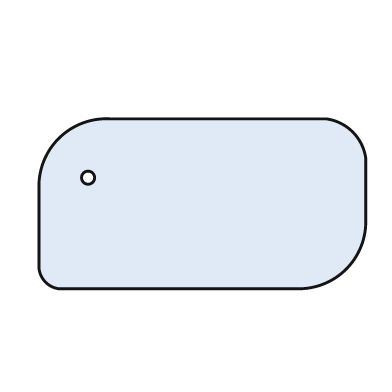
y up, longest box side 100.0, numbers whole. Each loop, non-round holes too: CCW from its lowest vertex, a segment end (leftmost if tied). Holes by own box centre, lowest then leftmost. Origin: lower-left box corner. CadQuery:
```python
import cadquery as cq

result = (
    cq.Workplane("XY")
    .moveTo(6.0, 0.0)
    .lineTo(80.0, 0.0)
    .threePointArc((94.0, 6.0), (100.0, 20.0))
    .lineTo(100.0, 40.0)
    .threePointArc((96.0, 48.0), (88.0, 52.0))
    .lineTo(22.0, 52.0)
    .threePointArc((6.0, 46.0), (0.0, 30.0))
    .lineTo(0.0, 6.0)
    .threePointArc((2.0, 2.0), (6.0, 0.0))
    .close()
    .moveTo(15.0, 34.0)
    .circle(2.0)
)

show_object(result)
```